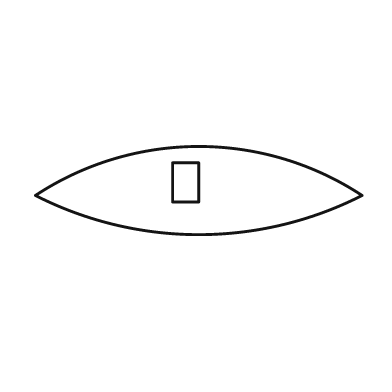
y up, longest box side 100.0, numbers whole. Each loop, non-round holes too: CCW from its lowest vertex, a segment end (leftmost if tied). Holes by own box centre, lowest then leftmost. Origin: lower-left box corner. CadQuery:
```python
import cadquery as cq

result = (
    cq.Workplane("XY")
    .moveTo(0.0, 12.0)
    .threePointArc((50.0, 0.0), (100.0, 12.0))
    .threePointArc((50.0, 27.0), (0.0, 12.0))
    .close()
    .moveTo(42.0, 10.0)
    .lineTo(50.0, 10.0)
    .lineTo(50.0, 22.0)
    .lineTo(42.0, 22.0)
    .close()
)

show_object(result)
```